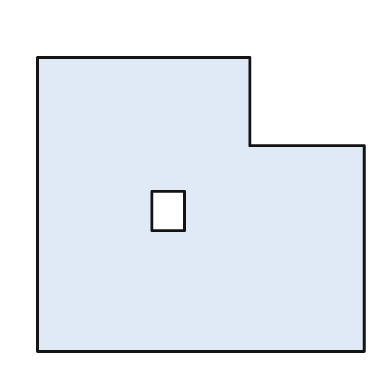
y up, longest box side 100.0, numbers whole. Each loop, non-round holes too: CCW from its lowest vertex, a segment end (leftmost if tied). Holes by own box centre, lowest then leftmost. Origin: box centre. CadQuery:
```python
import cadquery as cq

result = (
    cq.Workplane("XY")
    .moveTo(-50.0, -45.0)
    .lineTo(50.0, -45.0)
    .lineTo(50.0, 18.0)
    .lineTo(15.0, 18.0)
    .lineTo(15.0, 45.0)
    .lineTo(-50.0, 45.0)
    .close()
    .moveTo(-15.0, -8.0)
    .lineTo(-5.0, -8.0)
    .lineTo(-5.0, 4.0)
    .lineTo(-15.0, 4.0)
    .close()
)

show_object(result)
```